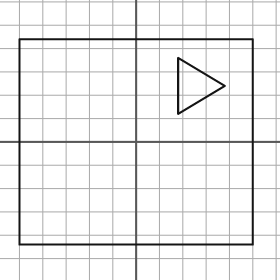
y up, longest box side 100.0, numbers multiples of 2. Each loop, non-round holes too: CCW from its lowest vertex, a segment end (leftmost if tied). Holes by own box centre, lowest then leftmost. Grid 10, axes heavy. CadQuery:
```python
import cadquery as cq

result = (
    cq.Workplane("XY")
    .moveTo(-50.0, -44.0)
    .lineTo(50.0, -44.0)
    .lineTo(50.0, 44.0)
    .lineTo(-50.0, 44.0)
    .close()
    .moveTo(18.0, 12.0)
    .lineTo(38.0, 24.0)
    .lineTo(18.0, 36.0)
    .close()
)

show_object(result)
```